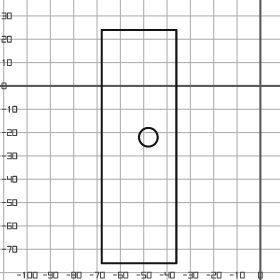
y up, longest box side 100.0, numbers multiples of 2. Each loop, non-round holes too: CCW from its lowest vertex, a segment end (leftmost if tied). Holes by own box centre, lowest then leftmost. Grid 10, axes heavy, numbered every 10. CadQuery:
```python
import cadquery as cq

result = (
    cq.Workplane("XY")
    .moveTo(-68.0, -76.0)
    .lineTo(-36.0, -76.0)
    .lineTo(-36.0, 24.0)
    .lineTo(-68.0, 24.0)
    .close()
    .moveTo(-48.0, -22.0)
    .circle(4.0)
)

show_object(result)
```